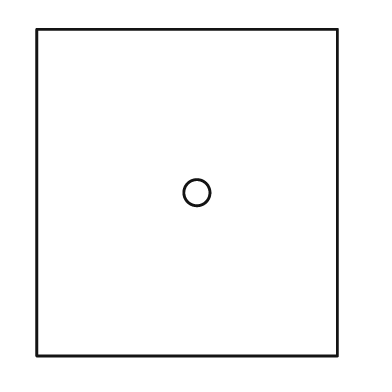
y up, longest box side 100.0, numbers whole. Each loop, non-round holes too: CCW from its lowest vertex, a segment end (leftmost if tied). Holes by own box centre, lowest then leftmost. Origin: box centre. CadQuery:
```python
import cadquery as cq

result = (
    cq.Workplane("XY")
    .moveTo(-46.0, -50.0)
    .lineTo(46.0, -50.0)
    .lineTo(46.0, 50.0)
    .lineTo(-46.0, 50.0)
    .close()
    .moveTo(3.0, 0.0)
    .circle(4.0)
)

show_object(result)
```